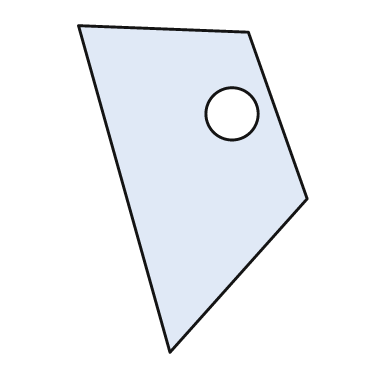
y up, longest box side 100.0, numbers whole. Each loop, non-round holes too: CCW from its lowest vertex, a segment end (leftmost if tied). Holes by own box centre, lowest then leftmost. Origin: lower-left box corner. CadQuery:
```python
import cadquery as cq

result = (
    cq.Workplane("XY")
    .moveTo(28.0, 0.0)
    .lineTo(70.0, 47.0)
    .lineTo(52.0, 98.0)
    .lineTo(0.0, 100.0)
    .close()
    .moveTo(47.0, 73.0)
    .circle(8.0)
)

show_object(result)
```